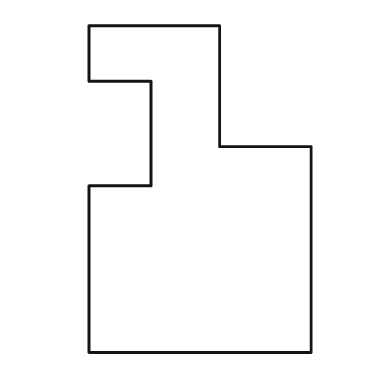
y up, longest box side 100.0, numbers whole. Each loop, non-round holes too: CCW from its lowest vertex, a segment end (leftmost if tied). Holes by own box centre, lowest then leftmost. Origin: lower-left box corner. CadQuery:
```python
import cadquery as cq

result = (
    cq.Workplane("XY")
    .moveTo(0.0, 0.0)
    .lineTo(68.0, 0.0)
    .lineTo(68.0, 63.0)
    .lineTo(40.0, 63.0)
    .lineTo(40.0, 100.0)
    .lineTo(0.0, 100.0)
    .lineTo(0.0, 83.0)
    .lineTo(19.0, 83.0)
    .lineTo(19.0, 51.0)
    .lineTo(0.0, 51.0)
    .close()
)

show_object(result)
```